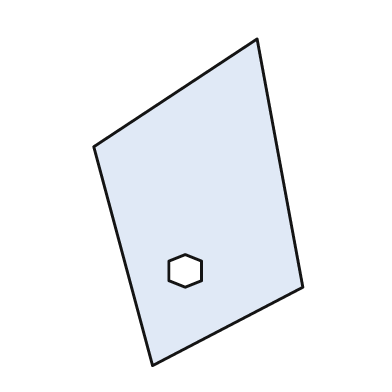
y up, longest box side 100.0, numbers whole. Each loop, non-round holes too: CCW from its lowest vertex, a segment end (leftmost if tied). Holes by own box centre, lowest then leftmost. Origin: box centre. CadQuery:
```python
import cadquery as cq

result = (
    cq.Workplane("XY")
    .moveTo(-14.0, -50.0)
    .lineTo(32.0, -26.0)
    .lineTo(18.0, 50.0)
    .lineTo(-32.0, 17.0)
    .close()
    .moveTo(-4.0, -26.0)
    .lineTo(1.0, -24.0)
    .lineTo(1.0, -18.0)
    .lineTo(-4.0, -16.0)
    .lineTo(-9.0, -18.0)
    .lineTo(-9.0, -24.0)
    .close()
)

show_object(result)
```